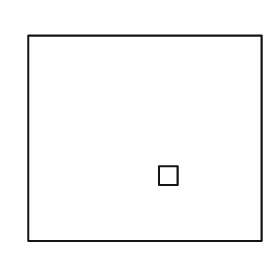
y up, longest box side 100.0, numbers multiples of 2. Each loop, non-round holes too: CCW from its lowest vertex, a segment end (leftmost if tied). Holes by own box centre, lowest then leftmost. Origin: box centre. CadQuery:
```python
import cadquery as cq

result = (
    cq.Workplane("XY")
    .moveTo(-50.0, -44.0)
    .lineTo(50.0, -44.0)
    .lineTo(50.0, 44.0)
    .lineTo(-50.0, 44.0)
    .close()
    .moveTo(6.0, -20.0)
    .lineTo(14.0, -20.0)
    .lineTo(14.0, -12.0)
    .lineTo(6.0, -12.0)
    .close()
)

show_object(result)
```